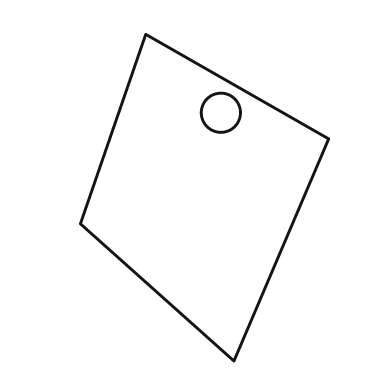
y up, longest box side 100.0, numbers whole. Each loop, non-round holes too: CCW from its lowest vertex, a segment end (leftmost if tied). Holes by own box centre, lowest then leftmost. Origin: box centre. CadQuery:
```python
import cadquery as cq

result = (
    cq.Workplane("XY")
    .moveTo(9.0, -50.0)
    .lineTo(38.0, 18.0)
    .lineTo(-18.0, 50.0)
    .lineTo(-38.0, -8.0)
    .close()
    .moveTo(5.0, 26.0)
    .circle(6.0)
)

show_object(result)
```